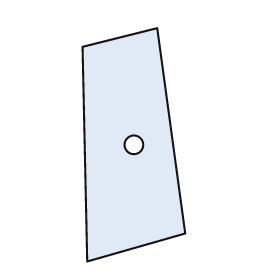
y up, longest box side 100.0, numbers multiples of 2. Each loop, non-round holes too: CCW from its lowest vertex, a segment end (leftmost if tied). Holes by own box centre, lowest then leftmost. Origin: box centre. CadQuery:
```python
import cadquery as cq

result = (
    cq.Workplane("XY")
    .moveTo(-20.0, -50.0)
    .lineTo(22.0, -38.0)
    .lineTo(10.0, 50.0)
    .lineTo(-22.0, 42.0)
    .close()
    .moveTo(0.0, 0.0)
    .circle(4.0)
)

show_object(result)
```